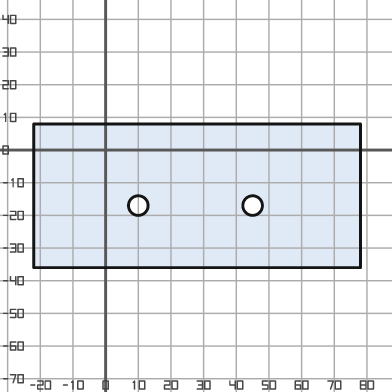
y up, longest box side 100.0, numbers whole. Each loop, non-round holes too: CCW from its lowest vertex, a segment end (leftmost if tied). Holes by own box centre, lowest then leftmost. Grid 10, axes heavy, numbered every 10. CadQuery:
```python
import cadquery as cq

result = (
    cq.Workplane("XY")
    .moveTo(-22.0, -36.0)
    .lineTo(78.0, -36.0)
    .lineTo(78.0, 8.0)
    .lineTo(-22.0, 8.0)
    .close()
    .moveTo(10.0, -17.0)
    .circle(3.0)
    .moveTo(45.0, -17.0)
    .circle(3.0)
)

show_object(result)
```